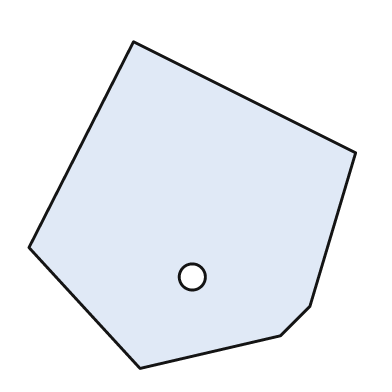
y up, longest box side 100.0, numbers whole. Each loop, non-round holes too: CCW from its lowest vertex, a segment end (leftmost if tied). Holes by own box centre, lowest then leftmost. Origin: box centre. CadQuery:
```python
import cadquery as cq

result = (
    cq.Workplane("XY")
    .moveTo(-16.0, -50.0)
    .lineTo(27.0, -40.0)
    .lineTo(36.0, -31.0)
    .lineTo(50.0, 16.0)
    .lineTo(-18.0, 50.0)
    .lineTo(-50.0, -13.0)
    .close()
    .moveTo(0.0, -22.0)
    .circle(4.0)
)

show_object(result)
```